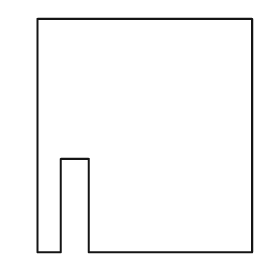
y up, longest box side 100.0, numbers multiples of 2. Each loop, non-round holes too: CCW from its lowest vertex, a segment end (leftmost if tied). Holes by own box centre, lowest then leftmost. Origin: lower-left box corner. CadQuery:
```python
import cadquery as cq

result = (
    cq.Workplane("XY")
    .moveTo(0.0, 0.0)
    .lineTo(10.0, 0.0)
    .lineTo(10.0, 40.0)
    .lineTo(22.0, 40.0)
    .lineTo(22.0, 0.0)
    .lineTo(92.0, 0.0)
    .lineTo(92.0, 100.0)
    .lineTo(0.0, 100.0)
    .close()
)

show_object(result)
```